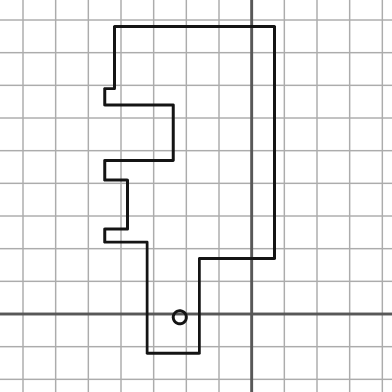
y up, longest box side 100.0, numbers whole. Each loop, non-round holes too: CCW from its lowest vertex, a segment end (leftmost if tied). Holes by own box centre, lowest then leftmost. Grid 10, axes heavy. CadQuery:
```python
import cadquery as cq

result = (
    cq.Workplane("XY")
    .moveTo(-32.0, -12.0)
    .lineTo(-16.0, -12.0)
    .lineTo(-16.0, 17.0)
    .lineTo(7.0, 17.0)
    .lineTo(7.0, 88.0)
    .lineTo(-42.0, 88.0)
    .lineTo(-42.0, 69.0)
    .lineTo(-45.0, 69.0)
    .lineTo(-45.0, 64.0)
    .lineTo(-24.0, 64.0)
    .lineTo(-24.0, 47.0)
    .lineTo(-45.0, 47.0)
    .lineTo(-45.0, 41.0)
    .lineTo(-38.0, 41.0)
    .lineTo(-38.0, 26.0)
    .lineTo(-45.0, 26.0)
    .lineTo(-45.0, 22.0)
    .lineTo(-32.0, 22.0)
    .close()
    .moveTo(-22.0, -1.0)
    .circle(2.0)
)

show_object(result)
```